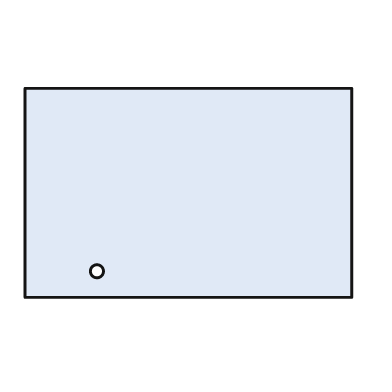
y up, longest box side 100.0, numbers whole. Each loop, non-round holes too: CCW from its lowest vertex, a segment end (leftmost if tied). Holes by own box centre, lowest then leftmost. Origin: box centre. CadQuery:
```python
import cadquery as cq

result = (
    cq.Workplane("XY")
    .moveTo(-50.0, -32.0)
    .lineTo(50.0, -32.0)
    .lineTo(50.0, 32.0)
    .lineTo(-50.0, 32.0)
    .close()
    .moveTo(-28.0, -24.0)
    .circle(2.0)
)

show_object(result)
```